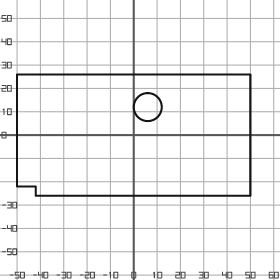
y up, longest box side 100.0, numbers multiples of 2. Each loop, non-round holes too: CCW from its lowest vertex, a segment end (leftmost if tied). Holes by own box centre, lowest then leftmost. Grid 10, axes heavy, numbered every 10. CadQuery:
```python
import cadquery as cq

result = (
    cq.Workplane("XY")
    .moveTo(-42.0, -26.0)
    .lineTo(50.0, -26.0)
    .lineTo(50.0, 26.0)
    .lineTo(-50.0, 26.0)
    .lineTo(-50.0, -22.0)
    .lineTo(-42.0, -22.0)
    .close()
    .moveTo(6.0, 12.0)
    .circle(6.0)
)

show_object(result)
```